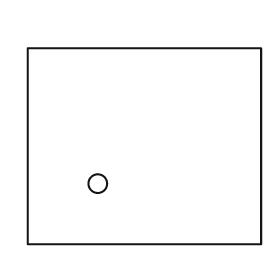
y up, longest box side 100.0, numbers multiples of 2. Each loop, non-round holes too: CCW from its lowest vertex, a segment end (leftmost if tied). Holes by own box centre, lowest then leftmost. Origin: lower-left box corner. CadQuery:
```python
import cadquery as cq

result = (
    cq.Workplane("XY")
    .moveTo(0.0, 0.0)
    .lineTo(100.0, 0.0)
    .lineTo(100.0, 84.0)
    .lineTo(0.0, 84.0)
    .close()
    .moveTo(30.0, 26.0)
    .circle(4.0)
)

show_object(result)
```